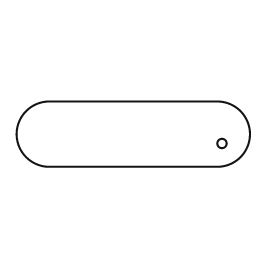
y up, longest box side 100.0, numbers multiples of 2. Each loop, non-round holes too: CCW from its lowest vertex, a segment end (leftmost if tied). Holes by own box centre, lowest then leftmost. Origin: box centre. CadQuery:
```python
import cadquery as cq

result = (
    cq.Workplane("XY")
    .moveTo(-36.0, -14.0)
    .lineTo(36.0, -14.0)
    .threePointArc((50.0, 0.0), (36.0, 14.0))
    .lineTo(-36.0, 14.0)
    .threePointArc((-50.0, 0.0), (-36.0, -14.0))
    .close()
    .moveTo(38.0, -4.0)
    .circle(2.0)
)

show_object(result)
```